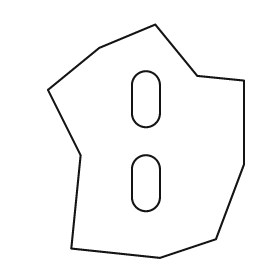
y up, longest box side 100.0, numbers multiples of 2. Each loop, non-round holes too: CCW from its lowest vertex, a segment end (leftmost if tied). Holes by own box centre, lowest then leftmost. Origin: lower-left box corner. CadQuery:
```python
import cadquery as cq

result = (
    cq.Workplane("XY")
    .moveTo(48.0, 0.0)
    .lineTo(72.0, 8.0)
    .lineTo(84.0, 40.0)
    .lineTo(84.0, 76.0)
    .lineTo(64.0, 78.0)
    .lineTo(46.0, 100.0)
    .lineTo(22.0, 90.0)
    .lineTo(0.0, 72.0)
    .lineTo(14.0, 44.0)
    .lineTo(10.0, 4.0)
    .close()
    .moveTo(36.0, 26.0)
    .threePointArc((42.0, 20.0), (48.0, 26.0))
    .lineTo(48.0, 38.0)
    .threePointArc((42.0, 44.0), (36.0, 38.0))
    .close()
    .moveTo(36.0, 62.0)
    .threePointArc((42.0, 56.0), (48.0, 62.0))
    .lineTo(48.0, 74.0)
    .threePointArc((42.0, 80.0), (36.0, 74.0))
    .close()
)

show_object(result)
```